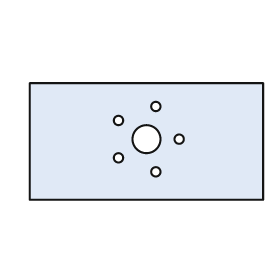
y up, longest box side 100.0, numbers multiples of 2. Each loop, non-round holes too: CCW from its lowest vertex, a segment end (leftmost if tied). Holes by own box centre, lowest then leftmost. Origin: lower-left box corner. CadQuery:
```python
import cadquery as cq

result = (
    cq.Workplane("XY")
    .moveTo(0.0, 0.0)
    .lineTo(100.0, 0.0)
    .lineTo(100.0, 50.0)
    .lineTo(0.0, 50.0)
    .close()
    .moveTo(54.0, 12.0)
    .circle(2.0)
    .moveTo(38.0, 18.0)
    .circle(2.0)
    .moveTo(50.0, 26.0)
    .circle(6.0)
    .moveTo(64.0, 26.0)
    .circle(2.0)
    .moveTo(38.0, 34.0)
    .circle(2.0)
    .moveTo(54.0, 40.0)
    .circle(2.0)
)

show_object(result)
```